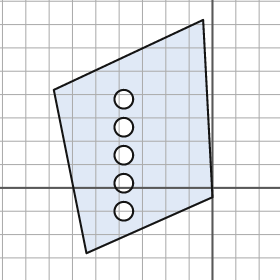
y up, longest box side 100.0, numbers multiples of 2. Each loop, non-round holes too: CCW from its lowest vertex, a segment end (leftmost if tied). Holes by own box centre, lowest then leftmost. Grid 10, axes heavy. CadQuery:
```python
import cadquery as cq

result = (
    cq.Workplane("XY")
    .moveTo(-54.0, -28.0)
    .lineTo(0.0, -4.0)
    .lineTo(-4.0, 72.0)
    .lineTo(-68.0, 42.0)
    .close()
    .moveTo(-38.0, -10.0)
    .circle(4.0)
    .moveTo(-38.0, 2.0)
    .circle(4.0)
    .moveTo(-38.0, 14.0)
    .circle(4.0)
    .moveTo(-38.0, 26.0)
    .circle(4.0)
    .moveTo(-38.0, 38.0)
    .circle(4.0)
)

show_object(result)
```